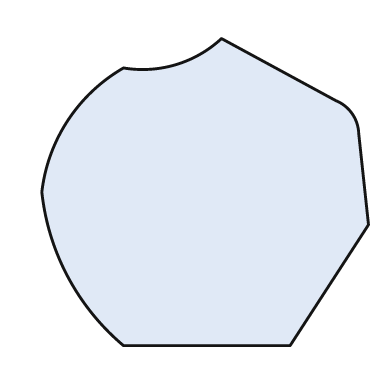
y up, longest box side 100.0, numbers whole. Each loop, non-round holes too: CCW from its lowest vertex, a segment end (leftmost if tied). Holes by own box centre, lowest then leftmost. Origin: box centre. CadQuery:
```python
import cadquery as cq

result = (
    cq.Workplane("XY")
    .moveTo(-25.0, -47.0)
    .lineTo(26.0, -47.0)
    .lineTo(50.0, -10.0)
    .lineTo(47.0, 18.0)
    .threePointArc((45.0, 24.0), (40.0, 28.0))
    .lineTo(5.0, 47.0)
    .threePointArc((-9.0, 39.0), (-25.0, 38.0))
    .threePointArc((-42.0, 22.0), (-50.0, 0.0))
    .threePointArc((-42.0, -26.0), (-25.0, -47.0))
    .close()
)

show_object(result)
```